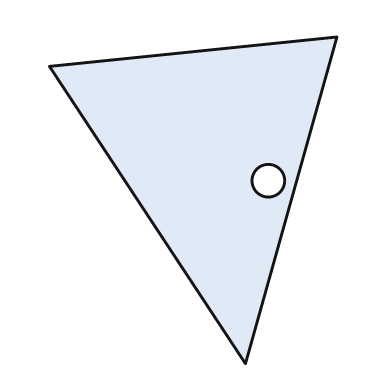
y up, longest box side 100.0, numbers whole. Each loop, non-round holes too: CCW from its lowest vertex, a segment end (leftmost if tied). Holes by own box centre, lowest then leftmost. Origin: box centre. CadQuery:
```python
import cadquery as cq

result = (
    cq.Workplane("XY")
    .moveTo(16.0, -50.0)
    .lineTo(44.0, 50.0)
    .lineTo(-44.0, 41.0)
    .close()
    .moveTo(23.0, 6.0)
    .circle(5.0)
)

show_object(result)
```